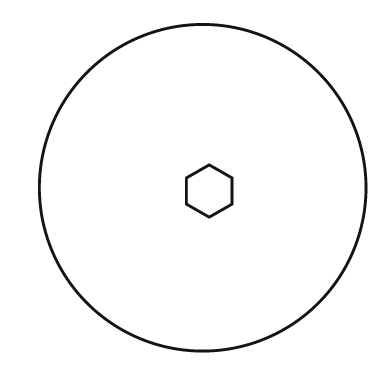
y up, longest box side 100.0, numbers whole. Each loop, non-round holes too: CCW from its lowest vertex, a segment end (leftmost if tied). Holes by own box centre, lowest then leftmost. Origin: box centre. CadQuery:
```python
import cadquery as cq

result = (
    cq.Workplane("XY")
    .moveTo(0.0, 0.0)
    .circle(50.0)
    .moveTo(2.0, -9.0)
    .lineTo(9.0, -5.0)
    .lineTo(9.0, 3.0)
    .lineTo(2.0, 7.0)
    .lineTo(-5.0, 3.0)
    .lineTo(-5.0, -5.0)
    .close()
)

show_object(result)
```